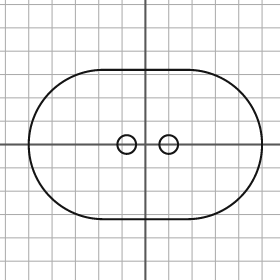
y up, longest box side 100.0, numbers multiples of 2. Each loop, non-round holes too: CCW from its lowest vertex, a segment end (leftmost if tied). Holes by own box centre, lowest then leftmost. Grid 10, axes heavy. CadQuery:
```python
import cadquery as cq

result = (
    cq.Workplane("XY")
    .moveTo(-18.0, -32.0)
    .lineTo(18.0, -32.0)
    .threePointArc((50.0, 0.0), (18.0, 32.0))
    .lineTo(-18.0, 32.0)
    .threePointArc((-50.0, 0.0), (-18.0, -32.0))
    .close()
    .moveTo(-8.0, 0.0)
    .circle(4.0)
    .moveTo(10.0, 0.0)
    .circle(4.0)
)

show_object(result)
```